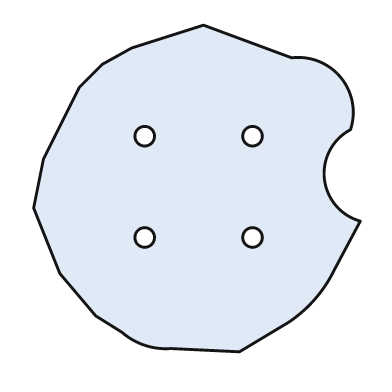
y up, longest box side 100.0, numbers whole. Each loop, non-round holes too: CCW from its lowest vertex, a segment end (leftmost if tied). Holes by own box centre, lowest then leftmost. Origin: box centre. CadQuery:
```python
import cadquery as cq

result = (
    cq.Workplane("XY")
    .moveTo(13.0, -50.0)
    .lineTo(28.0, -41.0)
    .threePointArc((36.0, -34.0), (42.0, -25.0))
    .lineTo(50.0, -10.0)
    .threePointArc((39.0, 3.0), (47.0, 18.0))
    .threePointArc((44.0, 34.0), (29.0, 40.0))
    .lineTo(2.0, 50.0)
    .lineTo(-20.0, 43.0)
    .lineTo(-29.0, 38.0)
    .lineTo(-36.0, 31.0)
    .lineTo(-47.0, 9.0)
    .lineTo(-50.0, -6.0)
    .lineTo(-42.0, -26.0)
    .lineTo(-31.0, -39.0)
    .lineTo(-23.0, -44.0)
    .threePointArc((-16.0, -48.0), (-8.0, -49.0))
    .close()
    .moveTo(-16.0, -15.0)
    .circle(3.0)
    .moveTo(17.0, -15.0)
    .circle(3.0)
    .moveTo(-16.0, 16.0)
    .circle(3.0)
    .moveTo(17.0, 16.0)
    .circle(3.0)
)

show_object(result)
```